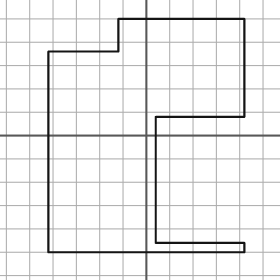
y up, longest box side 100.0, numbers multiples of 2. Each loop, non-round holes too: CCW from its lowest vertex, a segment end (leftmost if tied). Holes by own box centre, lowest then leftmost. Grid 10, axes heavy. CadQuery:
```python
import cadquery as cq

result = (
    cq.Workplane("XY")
    .moveTo(-42.0, -50.0)
    .lineTo(42.0, -50.0)
    .lineTo(42.0, -46.0)
    .lineTo(4.0, -46.0)
    .lineTo(4.0, 8.0)
    .lineTo(42.0, 8.0)
    .lineTo(42.0, 50.0)
    .lineTo(-12.0, 50.0)
    .lineTo(-12.0, 36.0)
    .lineTo(-42.0, 36.0)
    .close()
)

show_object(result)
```